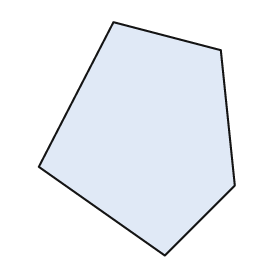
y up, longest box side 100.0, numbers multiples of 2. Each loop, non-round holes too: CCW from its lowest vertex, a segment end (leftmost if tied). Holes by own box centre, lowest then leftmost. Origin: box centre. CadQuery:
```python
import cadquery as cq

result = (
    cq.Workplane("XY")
    .moveTo(12.0, -50.0)
    .lineTo(42.0, -20.0)
    .lineTo(36.0, 38.0)
    .lineTo(-10.0, 50.0)
    .lineTo(-42.0, -12.0)
    .close()
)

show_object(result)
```